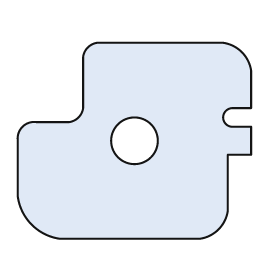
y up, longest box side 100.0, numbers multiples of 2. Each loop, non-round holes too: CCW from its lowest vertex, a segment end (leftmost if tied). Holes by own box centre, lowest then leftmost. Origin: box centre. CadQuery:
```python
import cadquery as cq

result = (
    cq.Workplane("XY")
    .moveTo(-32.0, -42.0)
    .lineTo(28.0, -42.0)
    .threePointArc((36.0, -38.0), (40.0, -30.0))
    .lineTo(40.0, -6.0)
    .lineTo(50.0, -6.0)
    .lineTo(50.0, 6.0)
    .lineTo(42.0, 6.0)
    .threePointArc((38.0, 10.0), (42.0, 14.0))
    .lineTo(50.0, 14.0)
    .lineTo(50.0, 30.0)
    .threePointArc((46.0, 38.0), (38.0, 42.0))
    .lineTo(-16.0, 42.0)
    .threePointArc((-20.0, 40.0), (-22.0, 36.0))
    .lineTo(-22.0, 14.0)
    .threePointArc((-24.0, 10.0), (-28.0, 8.0))
    .lineTo(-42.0, 8.0)
    .threePointArc((-48.0, 6.0), (-50.0, 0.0))
    .lineTo(-50.0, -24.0)
    .threePointArc((-44.0, -36.0), (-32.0, -42.0))
    .close()
    .moveTo(0.0, 0.0)
    .circle(10.0)
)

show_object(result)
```